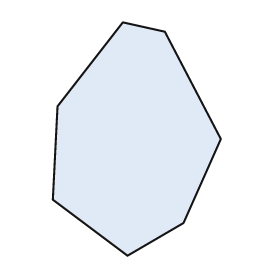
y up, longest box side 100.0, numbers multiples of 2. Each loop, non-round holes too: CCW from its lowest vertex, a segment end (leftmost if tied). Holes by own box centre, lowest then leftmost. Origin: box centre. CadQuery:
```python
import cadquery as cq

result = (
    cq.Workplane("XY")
    .moveTo(-4.0, -50.0)
    .lineTo(20.0, -36.0)
    .lineTo(36.0, 0.0)
    .lineTo(12.0, 46.0)
    .lineTo(-6.0, 50.0)
    .lineTo(-34.0, 14.0)
    .lineTo(-36.0, -26.0)
    .close()
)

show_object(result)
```